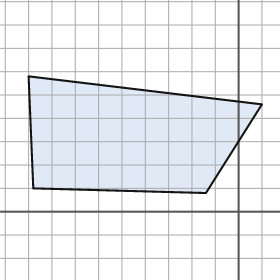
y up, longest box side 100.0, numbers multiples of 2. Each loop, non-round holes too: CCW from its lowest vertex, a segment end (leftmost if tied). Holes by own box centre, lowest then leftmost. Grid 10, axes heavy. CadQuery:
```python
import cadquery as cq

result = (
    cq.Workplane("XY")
    .moveTo(-14.0, 8.0)
    .lineTo(10.0, 46.0)
    .lineTo(-90.0, 58.0)
    .lineTo(-88.0, 10.0)
    .close()
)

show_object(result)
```